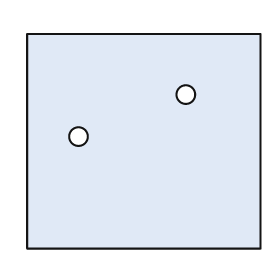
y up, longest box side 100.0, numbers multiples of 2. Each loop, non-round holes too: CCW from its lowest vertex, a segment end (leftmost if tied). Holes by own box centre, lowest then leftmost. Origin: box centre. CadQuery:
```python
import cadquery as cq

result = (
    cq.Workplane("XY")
    .moveTo(-50.0, -46.0)
    .lineTo(50.0, -46.0)
    .lineTo(50.0, 46.0)
    .lineTo(-50.0, 46.0)
    .close()
    .moveTo(-28.0, 2.0)
    .circle(4.0)
    .moveTo(18.0, 20.0)
    .circle(4.0)
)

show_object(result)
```